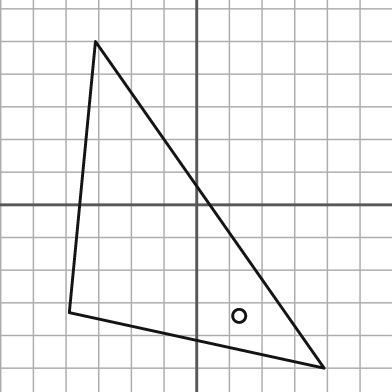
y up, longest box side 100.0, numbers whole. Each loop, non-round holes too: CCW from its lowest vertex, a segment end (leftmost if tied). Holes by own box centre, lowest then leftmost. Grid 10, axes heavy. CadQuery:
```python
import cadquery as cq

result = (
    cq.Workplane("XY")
    .moveTo(39.0, -50.0)
    .lineTo(-31.0, 50.0)
    .lineTo(-39.0, -33.0)
    .close()
    .moveTo(13.0, -34.0)
    .circle(2.0)
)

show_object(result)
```